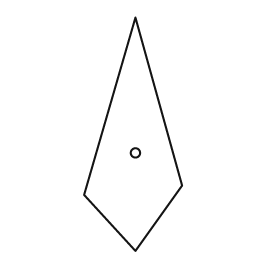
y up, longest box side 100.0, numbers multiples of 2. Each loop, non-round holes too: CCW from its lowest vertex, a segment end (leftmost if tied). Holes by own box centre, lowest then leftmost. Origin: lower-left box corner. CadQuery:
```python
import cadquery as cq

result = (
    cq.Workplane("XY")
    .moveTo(22.0, 0.0)
    .lineTo(42.0, 28.0)
    .lineTo(22.0, 100.0)
    .lineTo(0.0, 24.0)
    .close()
    .moveTo(22.0, 42.0)
    .circle(2.0)
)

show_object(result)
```